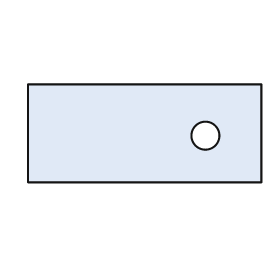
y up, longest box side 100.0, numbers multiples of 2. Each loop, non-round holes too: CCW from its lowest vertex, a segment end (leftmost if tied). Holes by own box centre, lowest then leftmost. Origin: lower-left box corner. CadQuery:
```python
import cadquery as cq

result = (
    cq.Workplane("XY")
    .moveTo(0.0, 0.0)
    .lineTo(100.0, 0.0)
    .lineTo(100.0, 42.0)
    .lineTo(0.0, 42.0)
    .close()
    .moveTo(76.0, 20.0)
    .circle(6.0)
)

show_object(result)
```